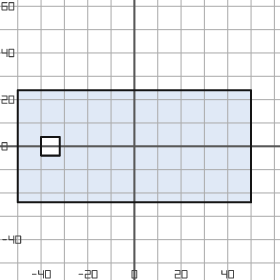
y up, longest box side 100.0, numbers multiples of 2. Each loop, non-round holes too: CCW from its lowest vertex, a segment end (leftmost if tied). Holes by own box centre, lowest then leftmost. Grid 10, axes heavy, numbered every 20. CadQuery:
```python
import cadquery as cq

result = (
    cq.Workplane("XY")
    .moveTo(-50.0, -24.0)
    .lineTo(50.0, -24.0)
    .lineTo(50.0, 24.0)
    .lineTo(-50.0, 24.0)
    .close()
    .moveTo(-40.0, -4.0)
    .lineTo(-32.0, -4.0)
    .lineTo(-32.0, 4.0)
    .lineTo(-40.0, 4.0)
    .close()
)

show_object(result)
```